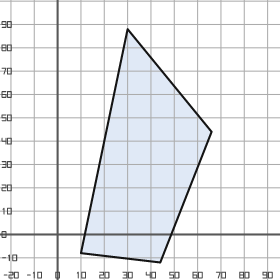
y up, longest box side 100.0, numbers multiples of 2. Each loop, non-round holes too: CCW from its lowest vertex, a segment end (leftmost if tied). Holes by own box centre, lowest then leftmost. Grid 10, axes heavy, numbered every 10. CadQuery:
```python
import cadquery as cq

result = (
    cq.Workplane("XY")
    .moveTo(44.0, -12.0)
    .lineTo(66.0, 44.0)
    .lineTo(30.0, 88.0)
    .lineTo(10.0, -8.0)
    .close()
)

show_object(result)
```